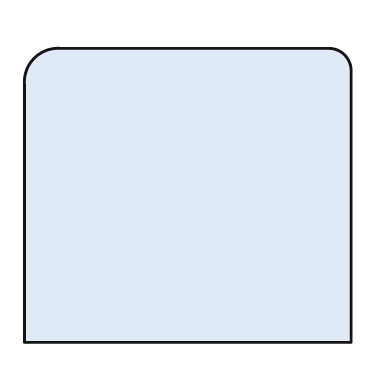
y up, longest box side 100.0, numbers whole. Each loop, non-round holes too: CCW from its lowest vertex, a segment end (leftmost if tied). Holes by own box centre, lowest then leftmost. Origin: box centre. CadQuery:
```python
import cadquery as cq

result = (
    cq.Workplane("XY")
    .moveTo(-50.0, -45.0)
    .lineTo(50.0, -45.0)
    .lineTo(50.0, 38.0)
    .threePointArc((48.0, 43.0), (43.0, 45.0))
    .lineTo(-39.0, 45.0)
    .threePointArc((-47.0, 42.0), (-50.0, 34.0))
    .close()
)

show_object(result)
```